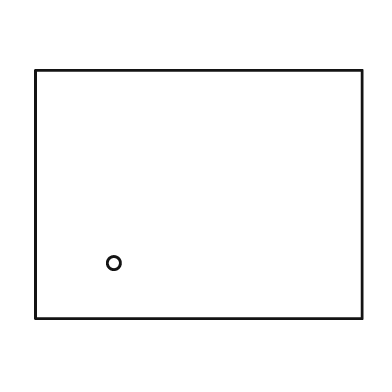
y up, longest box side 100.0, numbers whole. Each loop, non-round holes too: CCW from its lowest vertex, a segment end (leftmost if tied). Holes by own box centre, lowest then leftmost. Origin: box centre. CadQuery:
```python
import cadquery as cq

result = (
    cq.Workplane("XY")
    .moveTo(-50.0, -38.0)
    .lineTo(50.0, -38.0)
    .lineTo(50.0, 38.0)
    .lineTo(-50.0, 38.0)
    .close()
    .moveTo(-26.0, -21.0)
    .circle(2.0)
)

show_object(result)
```